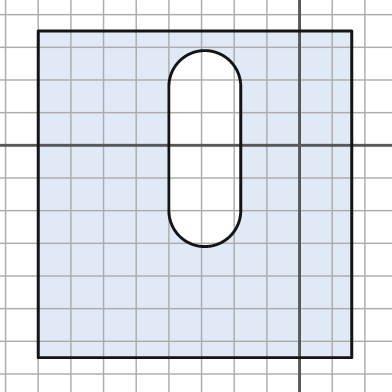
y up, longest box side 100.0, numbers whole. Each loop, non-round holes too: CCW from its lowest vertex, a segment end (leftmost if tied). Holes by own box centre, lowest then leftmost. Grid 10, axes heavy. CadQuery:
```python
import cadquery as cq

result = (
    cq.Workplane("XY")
    .moveTo(-80.0, -65.0)
    .lineTo(16.0, -65.0)
    .lineTo(16.0, 35.0)
    .lineTo(-80.0, 35.0)
    .close()
    .moveTo(-40.0, -20.0)
    .threePointArc((-29.0, -31.0), (-18.0, -20.0))
    .lineTo(-18.0, 18.0)
    .threePointArc((-29.0, 29.0), (-40.0, 18.0))
    .close()
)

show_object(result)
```